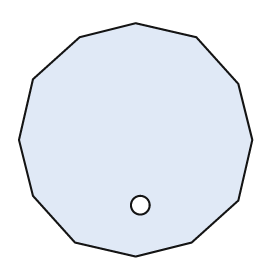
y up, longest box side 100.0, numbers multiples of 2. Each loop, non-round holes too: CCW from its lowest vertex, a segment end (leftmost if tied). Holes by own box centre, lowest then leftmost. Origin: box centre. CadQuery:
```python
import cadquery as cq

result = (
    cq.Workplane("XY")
    .moveTo(0.0, -50.0)
    .lineTo(24.0, -44.0)
    .lineTo(44.0, -26.0)
    .lineTo(50.0, 0.0)
    .lineTo(44.0, 24.0)
    .lineTo(26.0, 44.0)
    .lineTo(0.0, 50.0)
    .lineTo(-24.0, 44.0)
    .lineTo(-44.0, 26.0)
    .lineTo(-50.0, 0.0)
    .lineTo(-44.0, -24.0)
    .lineTo(-26.0, -44.0)
    .close()
    .moveTo(2.0, -28.0)
    .circle(4.0)
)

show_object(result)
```